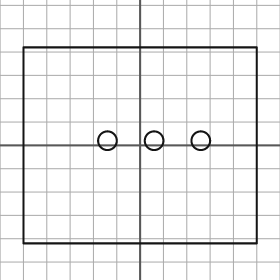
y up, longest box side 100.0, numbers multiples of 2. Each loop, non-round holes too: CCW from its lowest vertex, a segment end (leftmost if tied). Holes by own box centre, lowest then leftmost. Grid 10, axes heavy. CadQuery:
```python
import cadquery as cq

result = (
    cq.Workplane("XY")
    .moveTo(-50.0, -42.0)
    .lineTo(50.0, -42.0)
    .lineTo(50.0, 42.0)
    .lineTo(-50.0, 42.0)
    .close()
    .moveTo(-14.0, 2.0)
    .circle(4.0)
    .moveTo(6.0, 2.0)
    .circle(4.0)
    .moveTo(26.0, 2.0)
    .circle(4.0)
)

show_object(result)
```